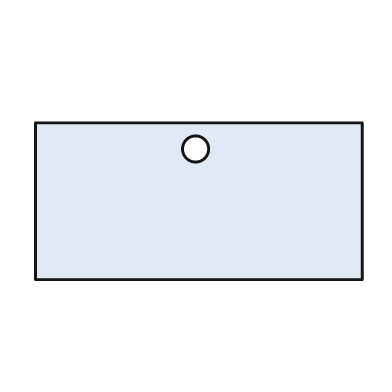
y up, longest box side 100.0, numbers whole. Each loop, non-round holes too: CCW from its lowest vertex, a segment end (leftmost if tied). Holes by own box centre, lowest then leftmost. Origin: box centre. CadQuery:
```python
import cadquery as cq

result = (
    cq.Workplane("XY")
    .moveTo(-50.0, -24.0)
    .lineTo(50.0, -24.0)
    .lineTo(50.0, 24.0)
    .lineTo(-50.0, 24.0)
    .close()
    .moveTo(-1.0, 16.0)
    .circle(4.0)
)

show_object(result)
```